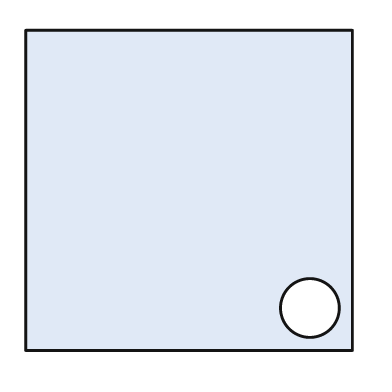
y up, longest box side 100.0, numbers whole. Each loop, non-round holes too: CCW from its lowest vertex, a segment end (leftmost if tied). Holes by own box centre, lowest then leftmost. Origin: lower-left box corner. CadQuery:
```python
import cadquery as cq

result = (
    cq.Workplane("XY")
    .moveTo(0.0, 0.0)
    .lineTo(100.0, 0.0)
    .lineTo(100.0, 98.0)
    .lineTo(0.0, 98.0)
    .close()
    .moveTo(87.0, 13.0)
    .circle(9.0)
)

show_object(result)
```